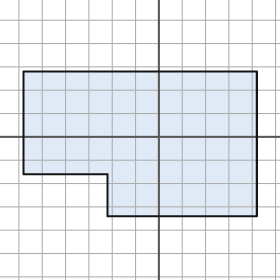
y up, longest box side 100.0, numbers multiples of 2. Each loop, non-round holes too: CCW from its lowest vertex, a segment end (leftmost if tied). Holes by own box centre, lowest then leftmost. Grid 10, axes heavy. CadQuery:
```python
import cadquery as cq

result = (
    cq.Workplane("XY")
    .moveTo(-22.0, -34.0)
    .lineTo(42.0, -34.0)
    .lineTo(42.0, 28.0)
    .lineTo(-58.0, 28.0)
    .lineTo(-58.0, -16.0)
    .lineTo(-22.0, -16.0)
    .close()
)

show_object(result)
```